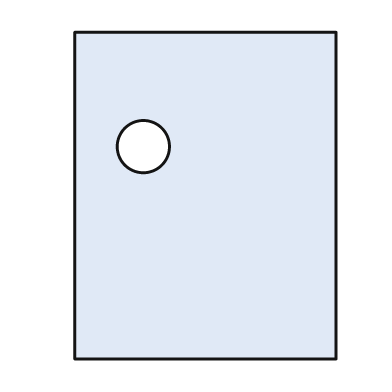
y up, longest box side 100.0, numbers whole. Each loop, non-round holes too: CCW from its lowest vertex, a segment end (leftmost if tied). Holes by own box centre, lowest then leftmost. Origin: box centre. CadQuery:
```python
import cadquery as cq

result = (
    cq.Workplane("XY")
    .moveTo(-40.0, -50.0)
    .lineTo(40.0, -50.0)
    .lineTo(40.0, 50.0)
    .lineTo(-40.0, 50.0)
    .close()
    .moveTo(-19.0, 15.0)
    .circle(8.0)
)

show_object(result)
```